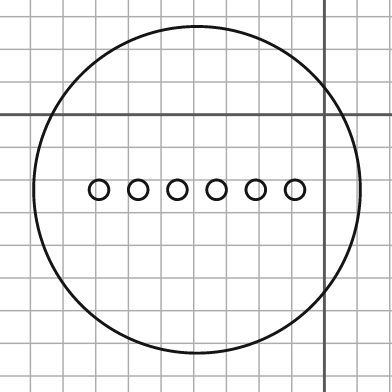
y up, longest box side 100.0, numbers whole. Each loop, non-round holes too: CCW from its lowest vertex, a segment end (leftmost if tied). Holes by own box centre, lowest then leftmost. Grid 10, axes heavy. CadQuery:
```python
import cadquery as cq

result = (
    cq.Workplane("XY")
    .moveTo(-39.0, -23.0)
    .circle(50.0)
    .moveTo(-69.0, -23.0)
    .circle(3.0)
    .moveTo(-57.0, -23.0)
    .circle(3.0)
    .moveTo(-45.0, -23.0)
    .circle(3.0)
    .moveTo(-33.0, -23.0)
    .circle(3.0)
    .moveTo(-21.0, -23.0)
    .circle(3.0)
    .moveTo(-9.0, -23.0)
    .circle(3.0)
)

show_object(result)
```